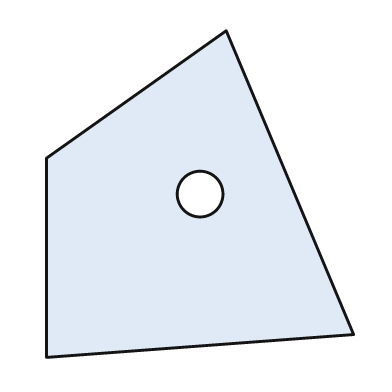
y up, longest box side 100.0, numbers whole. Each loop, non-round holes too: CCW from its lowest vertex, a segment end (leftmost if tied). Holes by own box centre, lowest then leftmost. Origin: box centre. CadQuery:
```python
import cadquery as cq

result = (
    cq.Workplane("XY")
    .moveTo(-47.0, -50.0)
    .lineTo(47.0, -43.0)
    .lineTo(8.0, 50.0)
    .lineTo(-47.0, 11.0)
    .close()
    .moveTo(0.0, 0.0)
    .circle(7.0)
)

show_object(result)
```